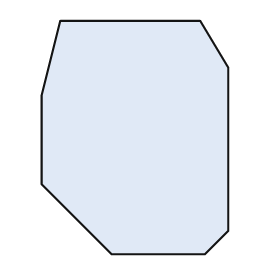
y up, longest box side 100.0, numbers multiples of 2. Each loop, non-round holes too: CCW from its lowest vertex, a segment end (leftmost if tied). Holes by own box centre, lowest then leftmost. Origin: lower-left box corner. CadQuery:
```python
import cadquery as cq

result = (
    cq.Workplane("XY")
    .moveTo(30.0, 0.0)
    .lineTo(70.0, 0.0)
    .lineTo(80.0, 10.0)
    .lineTo(80.0, 80.0)
    .lineTo(68.0, 100.0)
    .lineTo(8.0, 100.0)
    .lineTo(0.0, 68.0)
    .lineTo(0.0, 30.0)
    .close()
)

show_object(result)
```